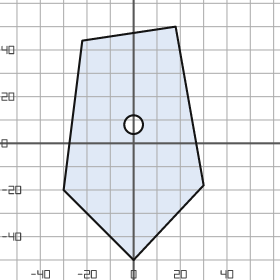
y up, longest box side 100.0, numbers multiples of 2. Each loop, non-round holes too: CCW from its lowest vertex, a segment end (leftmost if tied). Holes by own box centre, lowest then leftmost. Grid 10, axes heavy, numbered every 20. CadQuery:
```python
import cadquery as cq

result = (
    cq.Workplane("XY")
    .moveTo(0.0, -50.0)
    .lineTo(30.0, -18.0)
    .lineTo(18.0, 50.0)
    .lineTo(-22.0, 44.0)
    .lineTo(-30.0, -20.0)
    .close()
    .moveTo(0.0, 8.0)
    .circle(4.0)
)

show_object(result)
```